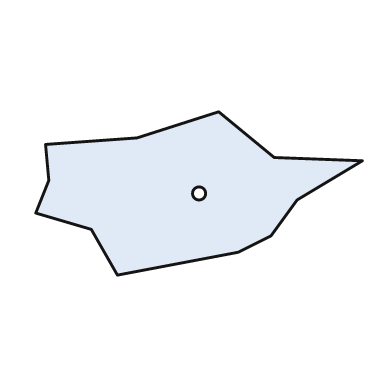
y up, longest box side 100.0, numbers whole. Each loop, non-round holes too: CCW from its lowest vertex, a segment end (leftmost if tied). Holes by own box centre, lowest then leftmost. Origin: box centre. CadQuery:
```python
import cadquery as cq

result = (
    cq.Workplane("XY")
    .moveTo(-25.0, -25.0)
    .lineTo(12.0, -18.0)
    .lineTo(22.0, -13.0)
    .lineTo(30.0, -2.0)
    .lineTo(50.0, 10.0)
    .lineTo(23.0, 11.0)
    .lineTo(6.0, 25.0)
    .lineTo(-19.0, 17.0)
    .lineTo(-47.0, 15.0)
    .lineTo(-46.0, 4.0)
    .lineTo(-50.0, -6.0)
    .lineTo(-33.0, -11.0)
    .close()
    .moveTo(0.0, 0.0)
    .circle(2.0)
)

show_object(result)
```